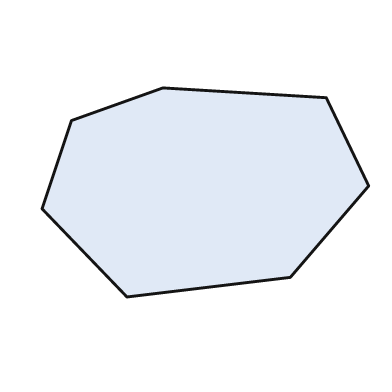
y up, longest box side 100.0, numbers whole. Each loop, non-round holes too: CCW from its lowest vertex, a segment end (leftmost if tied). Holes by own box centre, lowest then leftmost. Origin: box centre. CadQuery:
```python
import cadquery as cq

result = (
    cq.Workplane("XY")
    .moveTo(-24.0, -32.0)
    .lineTo(26.0, -26.0)
    .lineTo(50.0, 2.0)
    .lineTo(37.0, 29.0)
    .lineTo(-13.0, 32.0)
    .lineTo(-41.0, 22.0)
    .lineTo(-50.0, -5.0)
    .close()
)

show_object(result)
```